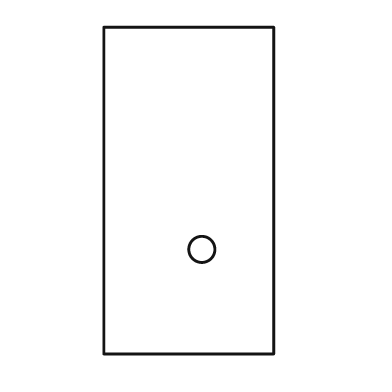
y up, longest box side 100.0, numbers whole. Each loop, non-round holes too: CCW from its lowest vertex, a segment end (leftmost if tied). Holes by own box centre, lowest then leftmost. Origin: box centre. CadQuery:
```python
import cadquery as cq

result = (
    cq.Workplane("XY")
    .moveTo(-26.0, -50.0)
    .lineTo(26.0, -50.0)
    .lineTo(26.0, 50.0)
    .lineTo(-26.0, 50.0)
    .close()
    .moveTo(4.0, -18.0)
    .circle(4.0)
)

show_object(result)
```